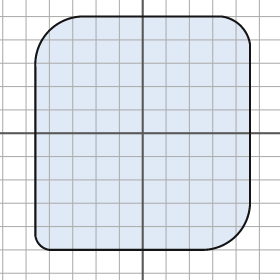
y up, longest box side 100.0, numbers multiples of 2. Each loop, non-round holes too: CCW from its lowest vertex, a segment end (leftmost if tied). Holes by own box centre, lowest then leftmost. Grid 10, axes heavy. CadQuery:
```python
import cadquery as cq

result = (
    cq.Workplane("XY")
    .moveTo(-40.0, -50.0)
    .lineTo(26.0, -50.0)
    .threePointArc((40.0, -44.0), (46.0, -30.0))
    .lineTo(46.0, 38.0)
    .threePointArc((42.0, 46.0), (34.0, 50.0))
    .lineTo(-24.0, 50.0)
    .threePointArc((-40.0, 44.0), (-46.0, 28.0))
    .lineTo(-46.0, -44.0)
    .threePointArc((-44.0, -48.0), (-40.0, -50.0))
    .close()
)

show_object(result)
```